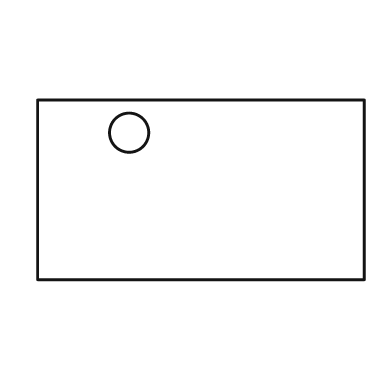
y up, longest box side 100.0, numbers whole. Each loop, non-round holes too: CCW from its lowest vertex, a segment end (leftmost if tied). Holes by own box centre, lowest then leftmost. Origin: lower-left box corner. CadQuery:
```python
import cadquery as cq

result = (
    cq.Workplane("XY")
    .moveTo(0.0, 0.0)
    .lineTo(100.0, 0.0)
    .lineTo(100.0, 55.0)
    .lineTo(0.0, 55.0)
    .close()
    .moveTo(28.0, 45.0)
    .circle(6.0)
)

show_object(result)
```